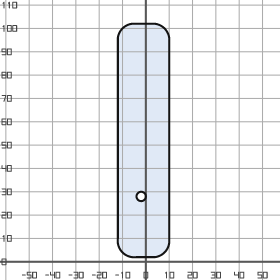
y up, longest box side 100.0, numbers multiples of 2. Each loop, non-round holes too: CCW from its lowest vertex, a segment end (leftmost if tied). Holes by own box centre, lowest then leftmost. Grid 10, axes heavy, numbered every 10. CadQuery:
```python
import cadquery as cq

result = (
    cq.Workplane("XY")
    .moveTo(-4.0, 2.0)
    .lineTo(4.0, 2.0)
    .threePointArc((8.0, 4.0), (10.0, 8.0))
    .lineTo(10.0, 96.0)
    .threePointArc((8.0, 100.0), (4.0, 102.0))
    .lineTo(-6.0, 102.0)
    .threePointArc((-10.0, 100.0), (-12.0, 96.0))
    .lineTo(-12.0, 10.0)
    .threePointArc((-10.0, 4.0), (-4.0, 2.0))
    .close()
    .moveTo(-2.0, 28.0)
    .circle(2.0)
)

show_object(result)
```